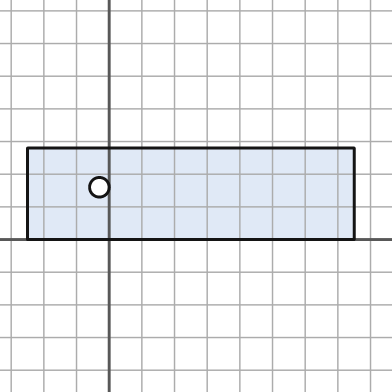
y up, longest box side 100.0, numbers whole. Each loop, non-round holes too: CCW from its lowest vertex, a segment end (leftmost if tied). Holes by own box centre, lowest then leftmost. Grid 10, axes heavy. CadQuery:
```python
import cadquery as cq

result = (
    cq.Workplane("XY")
    .moveTo(-25.0, 0.0)
    .lineTo(75.0, 0.0)
    .lineTo(75.0, 28.0)
    .lineTo(-25.0, 28.0)
    .close()
    .moveTo(-3.0, 16.0)
    .circle(3.0)
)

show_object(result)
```